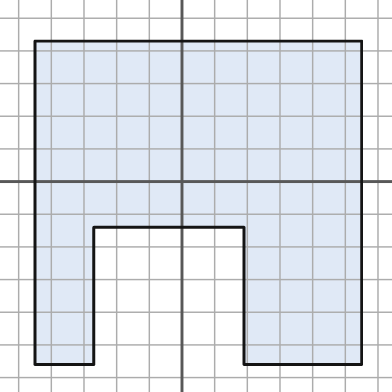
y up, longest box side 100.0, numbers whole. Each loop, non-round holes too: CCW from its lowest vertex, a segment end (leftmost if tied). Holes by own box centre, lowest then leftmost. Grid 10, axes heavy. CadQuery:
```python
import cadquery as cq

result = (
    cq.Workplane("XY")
    .moveTo(-45.0, -56.0)
    .lineTo(-27.0, -56.0)
    .lineTo(-27.0, -14.0)
    .lineTo(19.0, -14.0)
    .lineTo(19.0, -56.0)
    .lineTo(55.0, -56.0)
    .lineTo(55.0, 43.0)
    .lineTo(-45.0, 43.0)
    .close()
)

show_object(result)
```